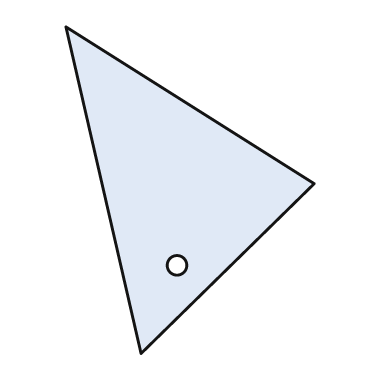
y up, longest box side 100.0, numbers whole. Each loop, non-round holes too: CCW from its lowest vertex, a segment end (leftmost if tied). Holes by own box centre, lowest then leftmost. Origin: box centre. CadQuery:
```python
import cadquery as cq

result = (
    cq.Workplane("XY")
    .moveTo(-15.0, -50.0)
    .lineTo(38.0, 2.0)
    .lineTo(-38.0, 50.0)
    .close()
    .moveTo(-4.0, -23.0)
    .circle(3.0)
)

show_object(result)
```